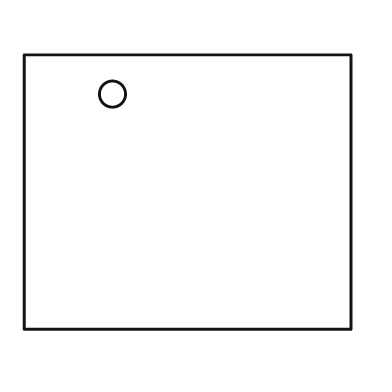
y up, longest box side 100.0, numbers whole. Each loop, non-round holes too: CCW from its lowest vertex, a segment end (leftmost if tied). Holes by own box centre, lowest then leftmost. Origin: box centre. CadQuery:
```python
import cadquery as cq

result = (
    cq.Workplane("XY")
    .moveTo(-50.0, -42.0)
    .lineTo(50.0, -42.0)
    .lineTo(50.0, 42.0)
    .lineTo(-50.0, 42.0)
    .close()
    .moveTo(-23.0, 30.0)
    .circle(4.0)
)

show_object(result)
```